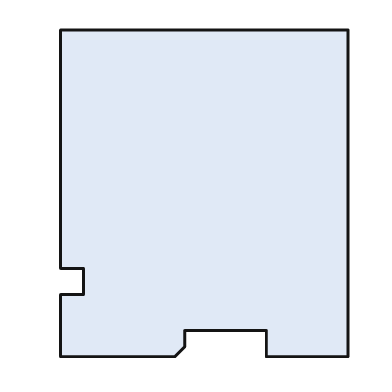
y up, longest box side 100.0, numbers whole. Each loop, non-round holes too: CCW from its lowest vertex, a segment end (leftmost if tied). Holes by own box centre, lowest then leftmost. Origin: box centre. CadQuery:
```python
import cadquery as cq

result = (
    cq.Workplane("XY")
    .moveTo(-44.0, -50.0)
    .lineTo(-9.0, -50.0)
    .lineTo(-6.0, -47.0)
    .lineTo(-6.0, -42.0)
    .lineTo(19.0, -42.0)
    .lineTo(19.0, -50.0)
    .lineTo(44.0, -50.0)
    .lineTo(44.0, 50.0)
    .lineTo(-44.0, 50.0)
    .lineTo(-44.0, -23.0)
    .lineTo(-37.0, -23.0)
    .lineTo(-37.0, -31.0)
    .lineTo(-44.0, -31.0)
    .close()
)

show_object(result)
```